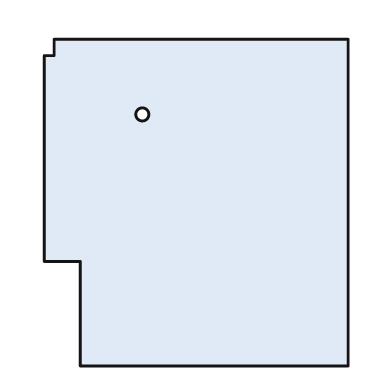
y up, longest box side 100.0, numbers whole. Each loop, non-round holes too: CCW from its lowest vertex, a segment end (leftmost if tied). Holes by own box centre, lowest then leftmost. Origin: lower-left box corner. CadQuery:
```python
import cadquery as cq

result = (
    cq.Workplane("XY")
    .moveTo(11.0, 0.0)
    .lineTo(93.0, 0.0)
    .lineTo(93.0, 100.0)
    .lineTo(3.0, 100.0)
    .lineTo(3.0, 95.0)
    .lineTo(0.0, 95.0)
    .lineTo(0.0, 32.0)
    .lineTo(11.0, 32.0)
    .close()
    .moveTo(30.0, 77.0)
    .circle(2.0)
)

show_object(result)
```